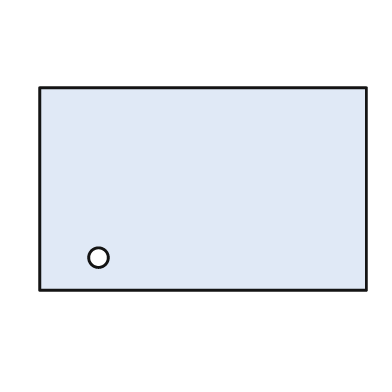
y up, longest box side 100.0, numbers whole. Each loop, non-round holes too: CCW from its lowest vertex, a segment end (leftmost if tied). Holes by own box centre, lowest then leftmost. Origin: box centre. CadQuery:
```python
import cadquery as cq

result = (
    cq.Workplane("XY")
    .moveTo(-50.0, -31.0)
    .lineTo(50.0, -31.0)
    .lineTo(50.0, 31.0)
    .lineTo(-50.0, 31.0)
    .close()
    .moveTo(-32.0, -21.0)
    .circle(3.0)
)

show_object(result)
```